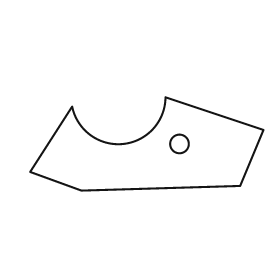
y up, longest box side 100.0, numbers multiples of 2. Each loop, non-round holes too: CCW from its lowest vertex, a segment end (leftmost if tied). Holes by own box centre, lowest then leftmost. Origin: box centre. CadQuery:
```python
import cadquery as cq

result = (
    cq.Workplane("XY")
    .moveTo(-28.0, -20.0)
    .lineTo(40.0, -18.0)
    .lineTo(50.0, 6.0)
    .lineTo(8.0, 20.0)
    .threePointArc((-10.0, 0.0), (-32.0, 16.0))
    .lineTo(-50.0, -12.0)
    .close()
    .moveTo(14.0, 0.0)
    .circle(4.0)
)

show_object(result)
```